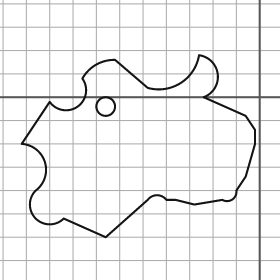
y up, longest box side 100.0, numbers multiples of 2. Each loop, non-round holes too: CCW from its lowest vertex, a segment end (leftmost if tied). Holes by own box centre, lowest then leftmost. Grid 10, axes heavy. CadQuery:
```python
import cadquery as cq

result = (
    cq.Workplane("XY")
    .moveTo(-66.0, -60.0)
    .lineTo(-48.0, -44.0)
    .threePointArc((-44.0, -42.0), (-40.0, -44.0))
    .lineTo(-36.0, -44.0)
    .lineTo(-28.0, -46.0)
    .lineTo(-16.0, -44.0)
    .threePointArc((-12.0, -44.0), (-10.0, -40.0))
    .lineTo(-6.0, -34.0)
    .lineTo(-2.0, -20.0)
    .lineTo(-2.0, -14.0)
    .lineTo(-6.0, -8.0)
    .lineTo(-24.0, 0.0)
    .threePointArc((-18.0, 10.0), (-26.0, 18.0))
    .threePointArc((-34.0, 6.0), (-48.0, 4.0))
    .lineTo(-62.0, 16.0)
    .threePointArc((-70.0, 14.0), (-76.0, 8.0))
    .threePointArc((-78.0, -4.0), (-90.0, -2.0))
    .lineTo(-102.0, -20.0)
    .threePointArc((-92.0, -28.0), (-96.0, -40.0))
    .threePointArc((-96.0, -52.0), (-84.0, -52.0))
    .close()
    .moveTo(-66.0, -4.0)
    .circle(4.0)
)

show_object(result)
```